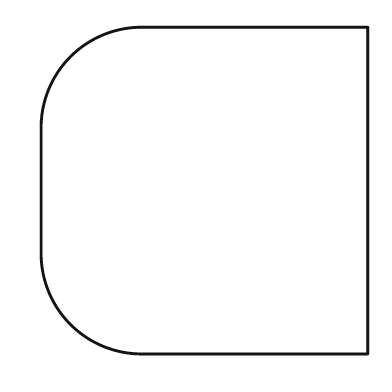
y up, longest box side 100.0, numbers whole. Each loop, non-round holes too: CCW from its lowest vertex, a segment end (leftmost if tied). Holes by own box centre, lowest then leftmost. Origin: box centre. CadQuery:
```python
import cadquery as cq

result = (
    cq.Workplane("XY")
    .moveTo(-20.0, -50.0)
    .lineTo(50.0, -50.0)
    .lineTo(50.0, 50.0)
    .lineTo(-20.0, 50.0)
    .threePointArc((-41.0, 41.0), (-50.0, 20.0))
    .lineTo(-50.0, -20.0)
    .threePointArc((-41.0, -41.0), (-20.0, -50.0))
    .close()
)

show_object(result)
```